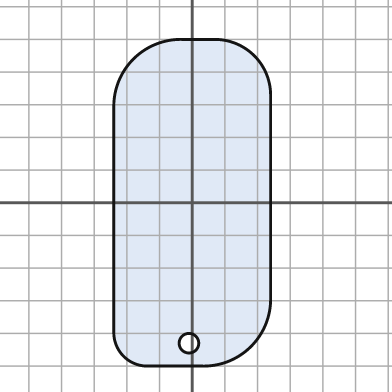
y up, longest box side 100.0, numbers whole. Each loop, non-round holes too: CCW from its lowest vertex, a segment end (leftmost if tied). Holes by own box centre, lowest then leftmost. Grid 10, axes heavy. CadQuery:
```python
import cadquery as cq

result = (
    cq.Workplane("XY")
    .moveTo(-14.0, -50.0)
    .lineTo(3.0, -50.0)
    .threePointArc((18.0, -44.0), (24.0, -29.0))
    .lineTo(24.0, 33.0)
    .threePointArc((19.0, 45.0), (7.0, 50.0))
    .lineTo(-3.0, 50.0)
    .threePointArc((-18.0, 44.0), (-24.0, 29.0))
    .lineTo(-24.0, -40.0)
    .threePointArc((-21.0, -47.0), (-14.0, -50.0))
    .close()
    .moveTo(-1.0, -43.0)
    .circle(3.0)
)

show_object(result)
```